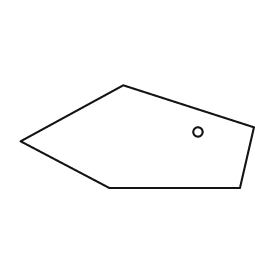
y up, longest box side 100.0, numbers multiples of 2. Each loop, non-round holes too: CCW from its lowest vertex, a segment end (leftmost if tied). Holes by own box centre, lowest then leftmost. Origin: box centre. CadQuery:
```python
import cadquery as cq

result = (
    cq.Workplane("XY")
    .moveTo(-12.0, -22.0)
    .lineTo(44.0, -22.0)
    .lineTo(50.0, 4.0)
    .lineTo(-6.0, 22.0)
    .lineTo(-50.0, -2.0)
    .close()
    .moveTo(26.0, 2.0)
    .circle(2.0)
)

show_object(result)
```